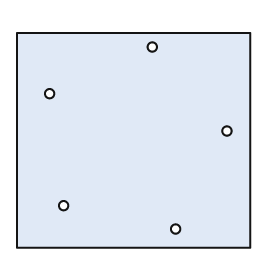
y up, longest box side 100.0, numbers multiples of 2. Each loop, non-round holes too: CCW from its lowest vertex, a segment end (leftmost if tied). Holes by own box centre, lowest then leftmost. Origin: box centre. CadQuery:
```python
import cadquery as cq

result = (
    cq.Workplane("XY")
    .moveTo(-50.0, -46.0)
    .lineTo(50.0, -46.0)
    .lineTo(50.0, 46.0)
    .lineTo(-50.0, 46.0)
    .close()
    .moveTo(18.0, -38.0)
    .circle(2.0)
    .moveTo(-30.0, -28.0)
    .circle(2.0)
    .moveTo(40.0, 4.0)
    .circle(2.0)
    .moveTo(-36.0, 20.0)
    .circle(2.0)
    .moveTo(8.0, 40.0)
    .circle(2.0)
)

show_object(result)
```